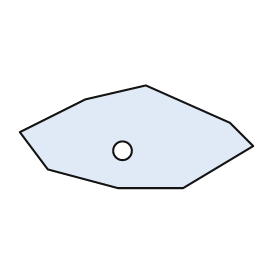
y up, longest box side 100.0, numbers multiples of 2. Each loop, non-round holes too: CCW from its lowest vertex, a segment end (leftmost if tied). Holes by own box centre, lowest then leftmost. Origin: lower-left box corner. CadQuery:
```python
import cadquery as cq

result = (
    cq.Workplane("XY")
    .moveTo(42.0, 0.0)
    .lineTo(70.0, 0.0)
    .lineTo(100.0, 18.0)
    .lineTo(90.0, 28.0)
    .lineTo(54.0, 44.0)
    .lineTo(28.0, 38.0)
    .lineTo(0.0, 24.0)
    .lineTo(12.0, 8.0)
    .close()
    .moveTo(44.0, 16.0)
    .circle(4.0)
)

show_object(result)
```